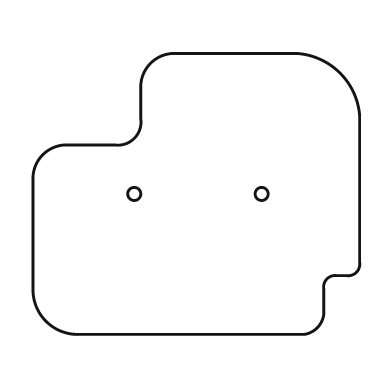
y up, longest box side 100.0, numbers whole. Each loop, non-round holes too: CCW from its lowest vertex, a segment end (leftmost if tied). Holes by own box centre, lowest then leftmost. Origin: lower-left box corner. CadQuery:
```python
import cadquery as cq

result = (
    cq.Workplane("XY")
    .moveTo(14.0, 0.0)
    .lineTo(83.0, 0.0)
    .threePointArc((87.0, 2.0), (89.0, 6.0))
    .lineTo(89.0, 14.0)
    .threePointArc((90.0, 17.0), (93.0, 18.0))
    .lineTo(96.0, 18.0)
    .threePointArc((99.0, 19.0), (100.0, 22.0))
    .lineTo(100.0, 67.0)
    .threePointArc((94.0, 80.0), (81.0, 86.0))
    .lineTo(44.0, 86.0)
    .threePointArc((36.0, 83.0), (33.0, 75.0))
    .lineTo(33.0, 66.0)
    .threePointArc((31.0, 60.0), (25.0, 58.0))
    .lineTo(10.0, 58.0)
    .threePointArc((3.0, 55.0), (0.0, 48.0))
    .lineTo(0.0, 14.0)
    .threePointArc((4.0, 4.0), (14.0, 0.0))
    .close()
    .moveTo(31.0, 43.0)
    .circle(2.0)
    .moveTo(70.0, 43.0)
    .circle(2.0)
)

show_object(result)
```